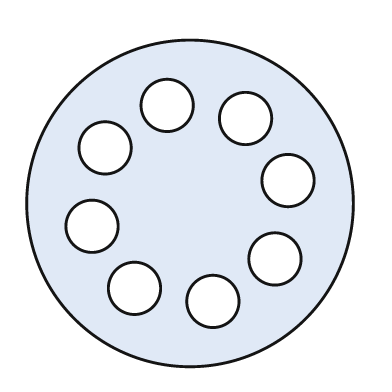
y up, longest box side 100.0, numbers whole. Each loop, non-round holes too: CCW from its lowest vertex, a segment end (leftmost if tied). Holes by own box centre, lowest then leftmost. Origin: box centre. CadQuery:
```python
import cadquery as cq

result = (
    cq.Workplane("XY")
    .moveTo(0.0, 0.0)
    .circle(50.0)
    .moveTo(7.0, -30.0)
    .circle(8.0)
    .moveTo(-17.0, -26.0)
    .circle(8.0)
    .moveTo(26.0, -17.0)
    .circle(8.0)
    .moveTo(-30.0, -7.0)
    .circle(8.0)
    .moveTo(30.0, 7.0)
    .circle(8.0)
    .moveTo(-26.0, 17.0)
    .circle(8.0)
    .moveTo(17.0, 26.0)
    .circle(8.0)
    .moveTo(-7.0, 30.0)
    .circle(8.0)
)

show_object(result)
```